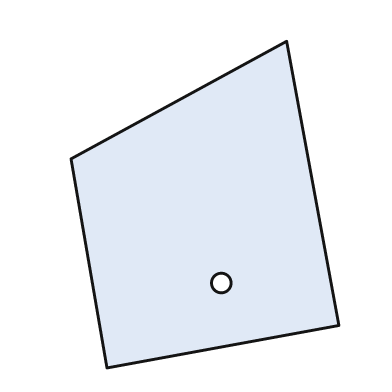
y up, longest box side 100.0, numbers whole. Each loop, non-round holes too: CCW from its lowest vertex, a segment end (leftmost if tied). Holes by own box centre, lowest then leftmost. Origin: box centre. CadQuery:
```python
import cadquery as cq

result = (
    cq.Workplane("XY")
    .moveTo(-30.0, -50.0)
    .lineTo(41.0, -37.0)
    .lineTo(25.0, 50.0)
    .lineTo(-41.0, 14.0)
    .close()
    .moveTo(5.0, -24.0)
    .circle(3.0)
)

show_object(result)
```